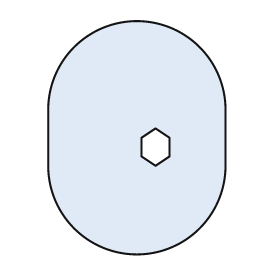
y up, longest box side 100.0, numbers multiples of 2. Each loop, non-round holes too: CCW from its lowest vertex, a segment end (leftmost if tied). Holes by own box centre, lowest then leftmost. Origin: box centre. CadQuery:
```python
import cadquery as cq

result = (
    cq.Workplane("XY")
    .moveTo(-38.0, -12.0)
    .threePointArc((0.0, -50.0), (38.0, -12.0))
    .lineTo(38.0, 12.0)
    .threePointArc((0.0, 50.0), (-38.0, 12.0))
    .close()
    .moveTo(8.0, -12.0)
    .lineTo(14.0, -8.0)
    .lineTo(14.0, 0.0)
    .lineTo(8.0, 4.0)
    .lineTo(2.0, 0.0)
    .lineTo(2.0, -8.0)
    .close()
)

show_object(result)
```